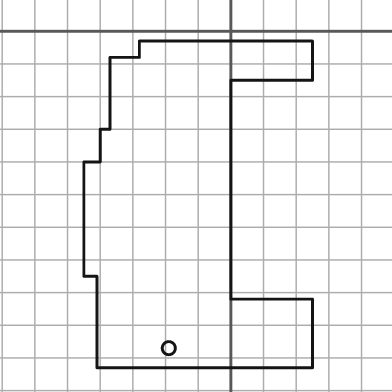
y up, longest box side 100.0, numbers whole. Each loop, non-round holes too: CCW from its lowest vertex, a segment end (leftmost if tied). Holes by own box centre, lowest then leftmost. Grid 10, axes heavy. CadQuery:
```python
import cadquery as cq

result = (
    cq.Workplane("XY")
    .moveTo(-41.0, -103.0)
    .lineTo(25.0, -103.0)
    .lineTo(25.0, -82.0)
    .lineTo(0.0, -82.0)
    .lineTo(0.0, -15.0)
    .lineTo(25.0, -15.0)
    .lineTo(25.0, -3.0)
    .lineTo(-28.0, -3.0)
    .lineTo(-28.0, -8.0)
    .lineTo(-37.0, -8.0)
    .lineTo(-37.0, -30.0)
    .lineTo(-40.0, -30.0)
    .lineTo(-40.0, -40.0)
    .lineTo(-45.0, -40.0)
    .lineTo(-45.0, -75.0)
    .lineTo(-41.0, -75.0)
    .close()
    .moveTo(-19.0, -97.0)
    .circle(2.0)
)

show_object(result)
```